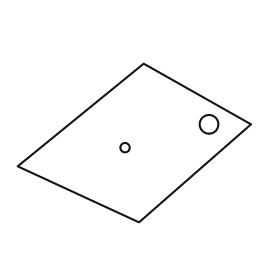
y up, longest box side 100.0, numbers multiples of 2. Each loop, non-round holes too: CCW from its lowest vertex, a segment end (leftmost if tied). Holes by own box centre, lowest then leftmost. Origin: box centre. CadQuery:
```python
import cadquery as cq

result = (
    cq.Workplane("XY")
    .moveTo(2.0, -34.0)
    .lineTo(50.0, 8.0)
    .lineTo(4.0, 34.0)
    .lineTo(-50.0, -10.0)
    .close()
    .moveTo(-4.0, -2.0)
    .circle(2.0)
    .moveTo(32.0, 8.0)
    .circle(4.0)
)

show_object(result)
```